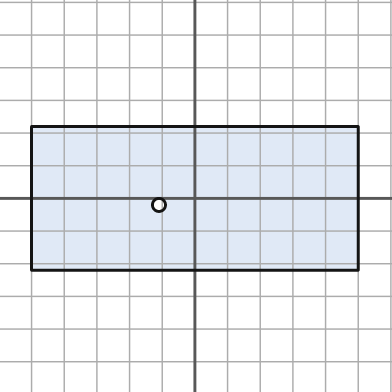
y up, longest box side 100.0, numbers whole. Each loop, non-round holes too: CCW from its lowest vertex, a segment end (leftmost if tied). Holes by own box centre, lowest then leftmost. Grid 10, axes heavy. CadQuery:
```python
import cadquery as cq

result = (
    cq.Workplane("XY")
    .moveTo(-50.0, -22.0)
    .lineTo(50.0, -22.0)
    .lineTo(50.0, 22.0)
    .lineTo(-50.0, 22.0)
    .close()
    .moveTo(-11.0, -2.0)
    .circle(2.0)
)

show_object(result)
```